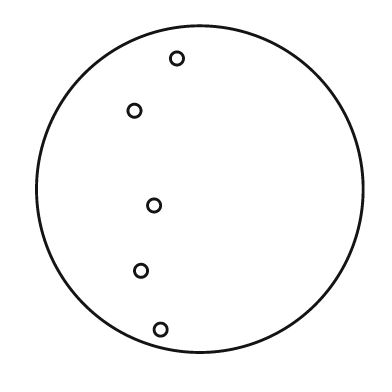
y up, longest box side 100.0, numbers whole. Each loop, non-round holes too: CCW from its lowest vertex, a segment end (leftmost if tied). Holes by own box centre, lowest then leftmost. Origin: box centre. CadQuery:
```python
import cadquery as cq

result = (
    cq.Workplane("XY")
    .moveTo(0.0, 0.0)
    .circle(50.0)
    .moveTo(-12.0, -43.0)
    .circle(2.0)
    .moveTo(-18.0, -25.0)
    .circle(2.0)
    .moveTo(-14.0, -5.0)
    .circle(2.0)
    .moveTo(-20.0, 24.0)
    .circle(2.0)
    .moveTo(-7.0, 40.0)
    .circle(2.0)
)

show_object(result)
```